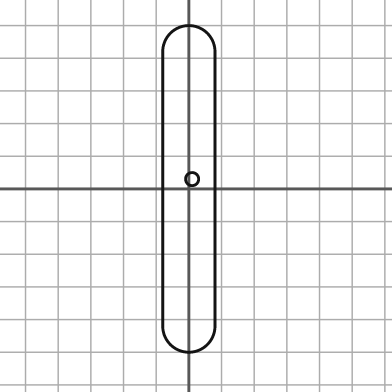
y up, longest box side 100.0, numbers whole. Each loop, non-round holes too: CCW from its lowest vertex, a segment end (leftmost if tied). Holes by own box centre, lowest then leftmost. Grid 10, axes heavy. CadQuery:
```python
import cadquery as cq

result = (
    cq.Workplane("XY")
    .moveTo(-8.0, -42.0)
    .threePointArc((0.0, -50.0), (8.0, -42.0))
    .lineTo(8.0, 42.0)
    .threePointArc((0.0, 50.0), (-8.0, 42.0))
    .close()
    .moveTo(1.0, 3.0)
    .circle(2.0)
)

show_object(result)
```